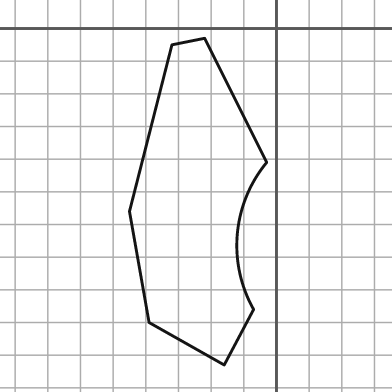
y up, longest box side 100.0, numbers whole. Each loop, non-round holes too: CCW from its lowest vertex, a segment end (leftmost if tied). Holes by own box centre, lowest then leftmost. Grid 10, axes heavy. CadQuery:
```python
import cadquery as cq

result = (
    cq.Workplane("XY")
    .moveTo(-16.0, -103.0)
    .lineTo(-7.0, -86.0)
    .threePointArc((-12.0, -63.0), (-3.0, -41.0))
    .lineTo(-22.0, -3.0)
    .lineTo(-32.0, -5.0)
    .lineTo(-45.0, -56.0)
    .lineTo(-39.0, -90.0)
    .close()
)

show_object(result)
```